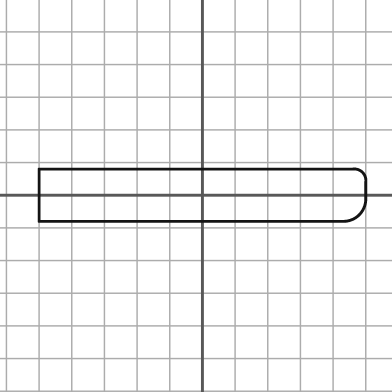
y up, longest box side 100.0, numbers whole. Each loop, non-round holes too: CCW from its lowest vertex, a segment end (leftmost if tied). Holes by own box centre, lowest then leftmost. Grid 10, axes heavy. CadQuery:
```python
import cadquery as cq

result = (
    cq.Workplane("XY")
    .moveTo(-50.0, -8.0)
    .lineTo(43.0, -8.0)
    .threePointArc((48.0, -6.0), (50.0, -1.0))
    .lineTo(50.0, 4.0)
    .threePointArc((49.0, 7.0), (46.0, 8.0))
    .lineTo(-50.0, 8.0)
    .close()
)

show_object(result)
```